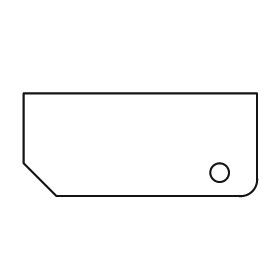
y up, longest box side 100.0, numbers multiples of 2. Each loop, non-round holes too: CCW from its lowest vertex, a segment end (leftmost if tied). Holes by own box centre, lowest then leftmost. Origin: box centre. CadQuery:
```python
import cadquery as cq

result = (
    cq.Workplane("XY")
    .moveTo(-36.0, -22.0)
    .lineTo(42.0, -22.0)
    .threePointArc((48.0, -20.0), (50.0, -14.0))
    .lineTo(50.0, 22.0)
    .lineTo(-50.0, 22.0)
    .lineTo(-50.0, -8.0)
    .close()
    .moveTo(34.0, -12.0)
    .circle(4.0)
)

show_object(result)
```